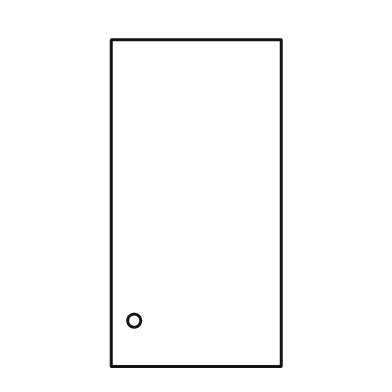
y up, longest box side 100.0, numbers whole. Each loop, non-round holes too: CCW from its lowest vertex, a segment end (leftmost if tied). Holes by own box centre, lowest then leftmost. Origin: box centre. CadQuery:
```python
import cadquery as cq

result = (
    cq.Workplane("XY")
    .moveTo(-26.0, -50.0)
    .lineTo(26.0, -50.0)
    .lineTo(26.0, 50.0)
    .lineTo(-26.0, 50.0)
    .close()
    .moveTo(-19.0, -36.0)
    .circle(2.0)
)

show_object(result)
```